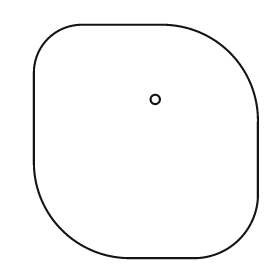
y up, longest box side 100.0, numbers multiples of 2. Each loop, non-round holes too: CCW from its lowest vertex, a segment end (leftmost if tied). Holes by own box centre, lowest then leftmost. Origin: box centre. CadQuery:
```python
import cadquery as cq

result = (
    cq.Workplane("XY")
    .moveTo(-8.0, -50.0)
    .lineTo(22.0, -50.0)
    .threePointArc((40.0, -42.0), (48.0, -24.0))
    .lineTo(48.0, 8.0)
    .threePointArc((36.0, 38.0), (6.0, 50.0))
    .lineTo(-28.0, 50.0)
    .threePointArc((-42.0, 44.0), (-48.0, 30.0))
    .lineTo(-48.0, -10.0)
    .threePointArc((-36.0, -38.0), (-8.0, -50.0))
    .close()
    .moveTo(4.0, 18.0)
    .circle(2.0)
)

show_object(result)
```